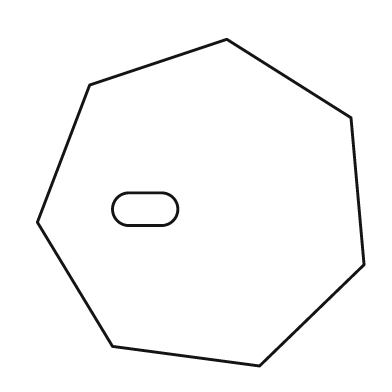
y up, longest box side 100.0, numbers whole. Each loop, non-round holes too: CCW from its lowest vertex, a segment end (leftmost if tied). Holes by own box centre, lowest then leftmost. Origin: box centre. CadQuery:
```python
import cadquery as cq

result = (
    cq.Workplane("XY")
    .moveTo(18.0, -50.0)
    .lineTo(50.0, -19.0)
    .lineTo(46.0, 26.0)
    .lineTo(8.0, 50.0)
    .lineTo(-34.0, 36.0)
    .lineTo(-50.0, -6.0)
    .lineTo(-27.0, -44.0)
    .close()
    .moveTo(-22.0, -7.0)
    .lineTo(-12.0, -7.0)
    .threePointArc((-7.0, -2.0), (-12.0, 3.0))
    .lineTo(-22.0, 3.0)
    .threePointArc((-27.0, -2.0), (-22.0, -7.0))
    .close()
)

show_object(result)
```